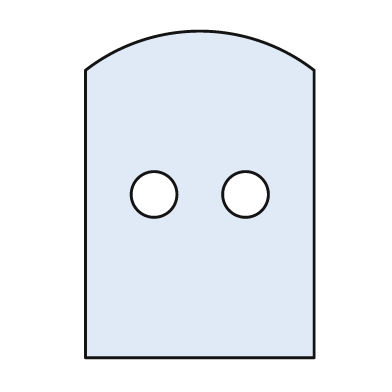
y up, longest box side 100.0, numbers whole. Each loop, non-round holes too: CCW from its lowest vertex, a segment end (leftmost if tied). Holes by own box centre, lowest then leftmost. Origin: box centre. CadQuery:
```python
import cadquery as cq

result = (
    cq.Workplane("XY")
    .moveTo(-35.0, -50.0)
    .lineTo(35.0, -50.0)
    .lineTo(35.0, 38.0)
    .threePointArc((0.0, 50.0), (-35.0, 38.0))
    .close()
    .moveTo(-14.0, 0.0)
    .circle(7.0)
    .moveTo(14.0, 0.0)
    .circle(7.0)
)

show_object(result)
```